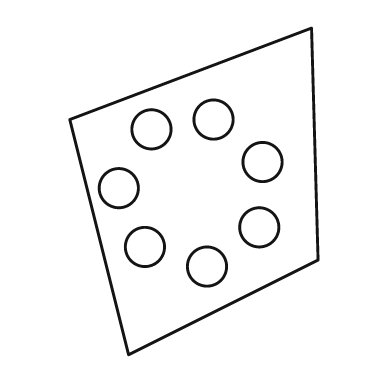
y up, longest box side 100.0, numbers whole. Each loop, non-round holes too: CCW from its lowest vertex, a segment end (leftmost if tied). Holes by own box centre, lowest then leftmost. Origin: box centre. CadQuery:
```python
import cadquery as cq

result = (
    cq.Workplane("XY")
    .moveTo(-20.0, -50.0)
    .lineTo(38.0, -21.0)
    .lineTo(36.0, 50.0)
    .lineTo(-38.0, 22.0)
    .close()
    .moveTo(4.0, -23.0)
    .circle(6.0)
    .moveTo(-15.0, -17.0)
    .circle(6.0)
    .moveTo(20.0, -11.0)
    .circle(6.0)
    .moveTo(-23.0, 1.0)
    .circle(6.0)
    .moveTo(21.0, 9.0)
    .circle(6.0)
    .moveTo(-13.0, 19.0)
    .circle(6.0)
    .moveTo(6.0, 22.0)
    .circle(6.0)
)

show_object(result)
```